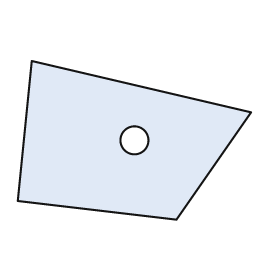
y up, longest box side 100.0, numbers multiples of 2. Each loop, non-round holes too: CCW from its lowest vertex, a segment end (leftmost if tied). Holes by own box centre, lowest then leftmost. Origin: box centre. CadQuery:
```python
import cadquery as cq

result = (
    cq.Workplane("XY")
    .moveTo(18.0, -34.0)
    .lineTo(50.0, 12.0)
    .lineTo(-44.0, 34.0)
    .lineTo(-50.0, -26.0)
    .close()
    .moveTo(0.0, 0.0)
    .circle(6.0)
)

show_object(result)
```